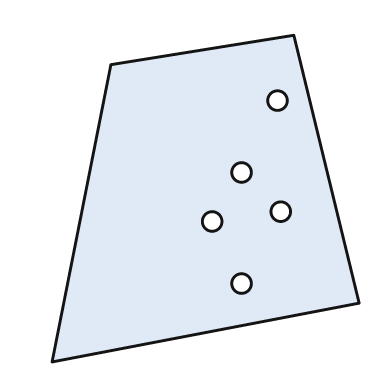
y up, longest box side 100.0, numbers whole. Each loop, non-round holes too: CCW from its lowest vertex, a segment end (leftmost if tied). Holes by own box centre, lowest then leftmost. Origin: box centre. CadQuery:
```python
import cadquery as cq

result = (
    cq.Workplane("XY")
    .moveTo(-47.0, -50.0)
    .lineTo(47.0, -32.0)
    .lineTo(27.0, 50.0)
    .lineTo(-29.0, 41.0)
    .close()
    .moveTo(11.0, -26.0)
    .circle(3.0)
    .moveTo(2.0, -7.0)
    .circle(3.0)
    .moveTo(23.0, -4.0)
    .circle(3.0)
    .moveTo(11.0, 8.0)
    .circle(3.0)
    .moveTo(22.0, 30.0)
    .circle(3.0)
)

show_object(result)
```